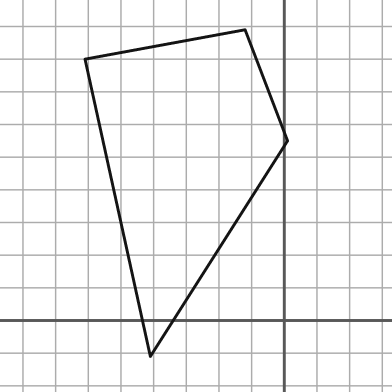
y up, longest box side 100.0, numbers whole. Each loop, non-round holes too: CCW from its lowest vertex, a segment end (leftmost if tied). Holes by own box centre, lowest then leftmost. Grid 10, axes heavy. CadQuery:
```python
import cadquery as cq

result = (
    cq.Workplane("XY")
    .moveTo(-41.0, -11.0)
    .lineTo(1.0, 55.0)
    .lineTo(-12.0, 89.0)
    .lineTo(-61.0, 80.0)
    .close()
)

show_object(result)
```